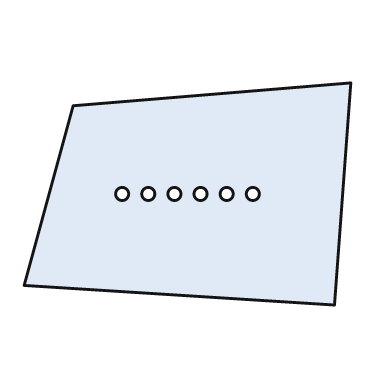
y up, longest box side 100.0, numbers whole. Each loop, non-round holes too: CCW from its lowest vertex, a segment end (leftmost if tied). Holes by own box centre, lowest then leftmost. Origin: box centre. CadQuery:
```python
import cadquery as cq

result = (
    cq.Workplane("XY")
    .moveTo(45.0, -34.0)
    .lineTo(50.0, 34.0)
    .lineTo(-35.0, 27.0)
    .lineTo(-50.0, -28.0)
    .close()
    .moveTo(-20.0, 0.0)
    .circle(2.0)
    .moveTo(-12.0, 0.0)
    .circle(2.0)
    .moveTo(-4.0, 0.0)
    .circle(2.0)
    .moveTo(4.0, 0.0)
    .circle(2.0)
    .moveTo(12.0, 0.0)
    .circle(2.0)
    .moveTo(20.0, 0.0)
    .circle(2.0)
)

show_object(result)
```